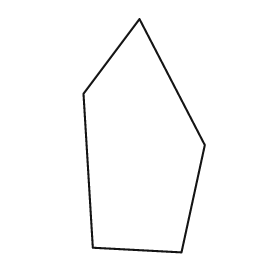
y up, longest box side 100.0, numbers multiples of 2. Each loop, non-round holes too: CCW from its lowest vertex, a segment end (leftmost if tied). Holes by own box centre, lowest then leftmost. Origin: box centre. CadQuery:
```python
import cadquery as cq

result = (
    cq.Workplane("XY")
    .moveTo(16.0, -50.0)
    .lineTo(26.0, -4.0)
    .lineTo(-2.0, 50.0)
    .lineTo(-26.0, 18.0)
    .lineTo(-22.0, -48.0)
    .close()
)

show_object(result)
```